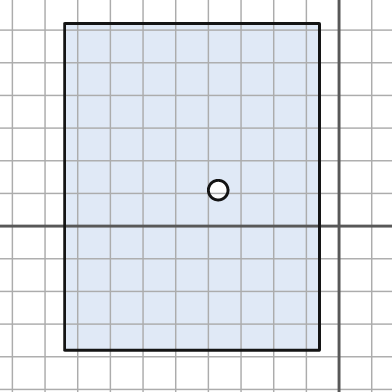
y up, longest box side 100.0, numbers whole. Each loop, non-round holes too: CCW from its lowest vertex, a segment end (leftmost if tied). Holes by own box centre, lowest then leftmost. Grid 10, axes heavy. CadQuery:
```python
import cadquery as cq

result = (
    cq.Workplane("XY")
    .moveTo(-84.0, -38.0)
    .lineTo(-6.0, -38.0)
    .lineTo(-6.0, 62.0)
    .lineTo(-84.0, 62.0)
    .close()
    .moveTo(-37.0, 11.0)
    .circle(3.0)
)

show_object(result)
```